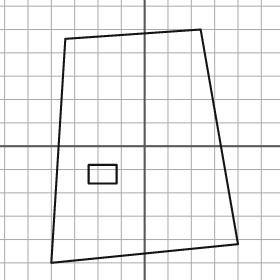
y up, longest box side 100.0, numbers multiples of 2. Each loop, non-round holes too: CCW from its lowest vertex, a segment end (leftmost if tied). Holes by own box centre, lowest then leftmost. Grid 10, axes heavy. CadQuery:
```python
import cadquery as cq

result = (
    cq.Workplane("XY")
    .moveTo(-40.0, -50.0)
    .lineTo(40.0, -42.0)
    .lineTo(24.0, 50.0)
    .lineTo(-34.0, 46.0)
    .close()
    .moveTo(-24.0, -16.0)
    .lineTo(-12.0, -16.0)
    .lineTo(-12.0, -8.0)
    .lineTo(-24.0, -8.0)
    .close()
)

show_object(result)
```